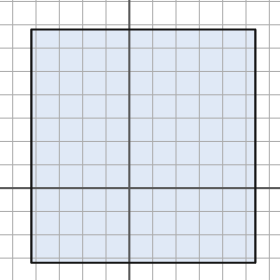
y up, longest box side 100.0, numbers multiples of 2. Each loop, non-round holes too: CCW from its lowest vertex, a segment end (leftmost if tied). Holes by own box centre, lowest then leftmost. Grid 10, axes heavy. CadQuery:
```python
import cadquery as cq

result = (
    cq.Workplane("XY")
    .moveTo(-42.0, -32.0)
    .lineTo(54.0, -32.0)
    .lineTo(54.0, 68.0)
    .lineTo(-42.0, 68.0)
    .close()
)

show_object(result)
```